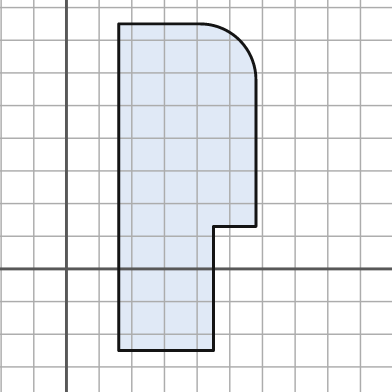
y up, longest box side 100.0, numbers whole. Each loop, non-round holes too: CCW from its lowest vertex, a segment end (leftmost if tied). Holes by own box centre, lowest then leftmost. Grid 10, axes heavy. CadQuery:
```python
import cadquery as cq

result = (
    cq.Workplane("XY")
    .moveTo(16.0, -25.0)
    .lineTo(45.0, -25.0)
    .lineTo(45.0, 13.0)
    .lineTo(58.0, 13.0)
    .lineTo(58.0, 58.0)
    .threePointArc((53.0, 70.0), (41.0, 75.0))
    .lineTo(16.0, 75.0)
    .close()
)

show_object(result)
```